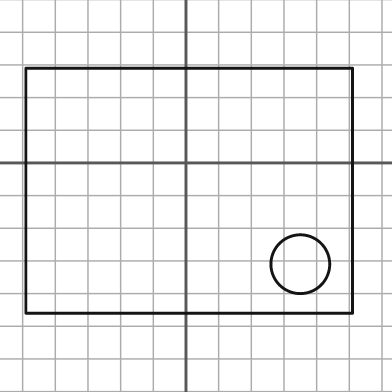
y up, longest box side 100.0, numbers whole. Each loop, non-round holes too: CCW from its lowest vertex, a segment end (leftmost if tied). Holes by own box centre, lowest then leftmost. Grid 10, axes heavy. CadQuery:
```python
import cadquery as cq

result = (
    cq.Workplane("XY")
    .moveTo(-49.0, -46.0)
    .lineTo(51.0, -46.0)
    .lineTo(51.0, 29.0)
    .lineTo(-49.0, 29.0)
    .close()
    .moveTo(35.0, -31.0)
    .circle(9.0)
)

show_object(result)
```